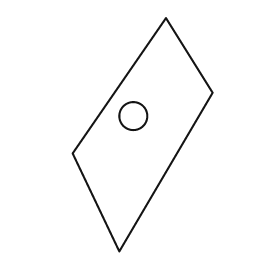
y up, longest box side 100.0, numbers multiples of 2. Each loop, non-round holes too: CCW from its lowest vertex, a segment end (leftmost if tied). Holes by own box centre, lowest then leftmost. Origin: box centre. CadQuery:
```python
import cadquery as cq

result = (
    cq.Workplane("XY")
    .moveTo(-10.0, -50.0)
    .lineTo(30.0, 18.0)
    .lineTo(10.0, 50.0)
    .lineTo(-30.0, -8.0)
    .close()
    .moveTo(-4.0, 8.0)
    .circle(6.0)
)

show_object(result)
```